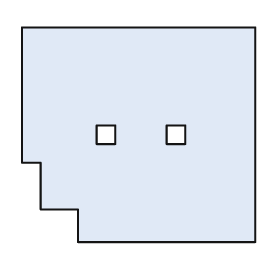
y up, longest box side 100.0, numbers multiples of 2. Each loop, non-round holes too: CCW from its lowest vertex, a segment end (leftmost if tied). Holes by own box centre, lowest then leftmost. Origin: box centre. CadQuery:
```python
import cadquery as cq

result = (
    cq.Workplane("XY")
    .moveTo(-26.0, -46.0)
    .lineTo(50.0, -46.0)
    .lineTo(50.0, 46.0)
    .lineTo(-50.0, 46.0)
    .lineTo(-50.0, -12.0)
    .lineTo(-42.0, -12.0)
    .lineTo(-42.0, -32.0)
    .lineTo(-26.0, -32.0)
    .close()
    .moveTo(-18.0, -4.0)
    .lineTo(-10.0, -4.0)
    .lineTo(-10.0, 4.0)
    .lineTo(-18.0, 4.0)
    .close()
    .moveTo(12.0, -4.0)
    .lineTo(20.0, -4.0)
    .lineTo(20.0, 4.0)
    .lineTo(12.0, 4.0)
    .close()
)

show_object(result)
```